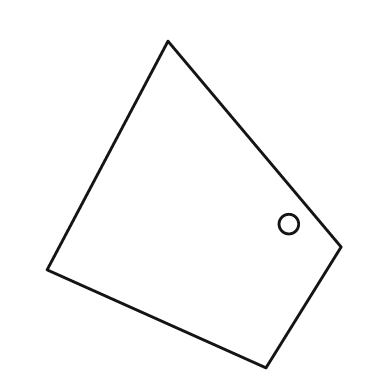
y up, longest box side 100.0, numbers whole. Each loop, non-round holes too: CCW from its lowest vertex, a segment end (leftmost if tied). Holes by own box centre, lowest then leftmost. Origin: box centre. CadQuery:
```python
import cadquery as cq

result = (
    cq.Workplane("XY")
    .moveTo(22.0, -50.0)
    .lineTo(45.0, -13.0)
    .lineTo(-8.0, 50.0)
    .lineTo(-45.0, -20.0)
    .close()
    .moveTo(29.0, -6.0)
    .circle(3.0)
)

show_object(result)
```